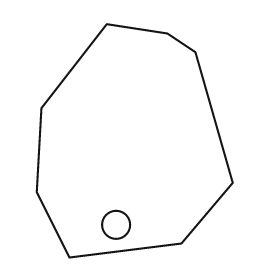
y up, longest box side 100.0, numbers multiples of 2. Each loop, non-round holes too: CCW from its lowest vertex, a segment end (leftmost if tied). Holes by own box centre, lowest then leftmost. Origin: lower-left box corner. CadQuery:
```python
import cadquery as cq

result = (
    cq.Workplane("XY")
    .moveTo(14.0, 0.0)
    .lineTo(62.0, 6.0)
    .lineTo(84.0, 32.0)
    .lineTo(68.0, 88.0)
    .lineTo(56.0, 96.0)
    .lineTo(30.0, 100.0)
    .lineTo(2.0, 64.0)
    .lineTo(0.0, 28.0)
    .close()
    .moveTo(34.0, 14.0)
    .circle(6.0)
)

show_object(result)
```